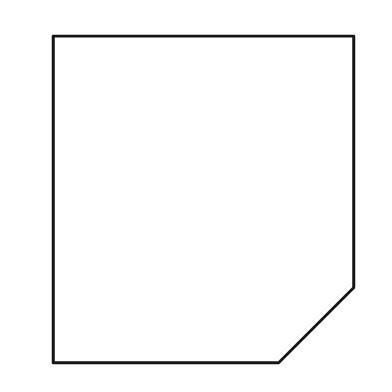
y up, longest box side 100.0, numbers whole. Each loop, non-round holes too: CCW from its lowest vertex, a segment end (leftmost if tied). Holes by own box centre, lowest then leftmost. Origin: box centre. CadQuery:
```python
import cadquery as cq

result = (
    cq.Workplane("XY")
    .moveTo(-46.0, -50.0)
    .lineTo(23.0, -50.0)
    .lineTo(46.0, -27.0)
    .lineTo(46.0, 50.0)
    .lineTo(-46.0, 50.0)
    .close()
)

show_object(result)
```